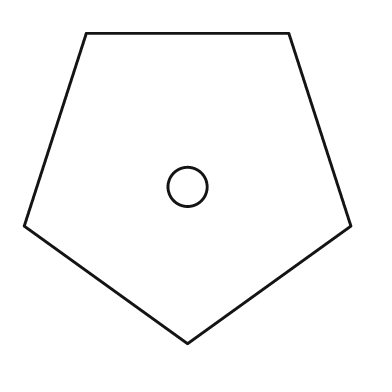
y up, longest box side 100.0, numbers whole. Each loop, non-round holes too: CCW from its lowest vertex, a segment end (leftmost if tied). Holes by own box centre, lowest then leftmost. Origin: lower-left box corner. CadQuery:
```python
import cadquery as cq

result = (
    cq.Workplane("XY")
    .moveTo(50.0, 0.0)
    .lineTo(100.0, 36.0)
    .lineTo(81.0, 95.0)
    .lineTo(19.0, 95.0)
    .lineTo(0.0, 36.0)
    .close()
    .moveTo(50.0, 48.0)
    .circle(6.0)
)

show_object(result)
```